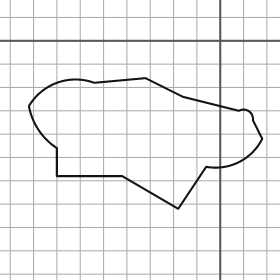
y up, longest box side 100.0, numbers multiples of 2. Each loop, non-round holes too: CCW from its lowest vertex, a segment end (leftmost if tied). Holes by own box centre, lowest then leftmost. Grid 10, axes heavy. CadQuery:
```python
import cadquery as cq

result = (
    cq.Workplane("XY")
    .moveTo(-18.0, -72.0)
    .lineTo(-6.0, -54.0)
    .threePointArc((8.0, -52.0), (18.0, -42.0))
    .lineTo(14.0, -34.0)
    .threePointArc((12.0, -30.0), (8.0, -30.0))
    .lineTo(-16.0, -24.0)
    .lineTo(-32.0, -16.0)
    .lineTo(-54.0, -18.0)
    .threePointArc((-70.0, -18.0), (-82.0, -28.0))
    .threePointArc((-78.0, -38.0), (-70.0, -46.0))
    .lineTo(-70.0, -58.0)
    .lineTo(-42.0, -58.0)
    .close()
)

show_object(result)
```